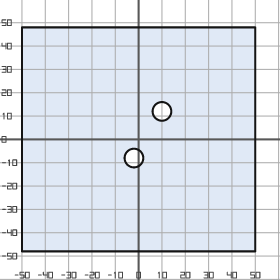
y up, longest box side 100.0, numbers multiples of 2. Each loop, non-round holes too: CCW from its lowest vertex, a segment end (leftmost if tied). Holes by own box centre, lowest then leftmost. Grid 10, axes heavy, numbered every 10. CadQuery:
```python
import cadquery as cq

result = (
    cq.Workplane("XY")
    .moveTo(-50.0, -48.0)
    .lineTo(50.0, -48.0)
    .lineTo(50.0, 48.0)
    .lineTo(-50.0, 48.0)
    .close()
    .moveTo(-2.0, -8.0)
    .circle(4.0)
    .moveTo(10.0, 12.0)
    .circle(4.0)
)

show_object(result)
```